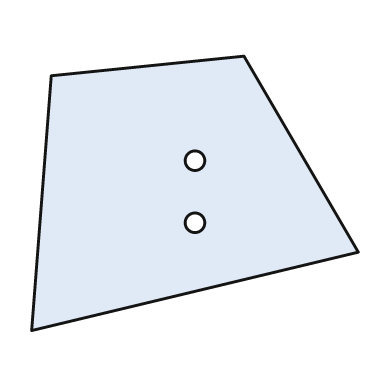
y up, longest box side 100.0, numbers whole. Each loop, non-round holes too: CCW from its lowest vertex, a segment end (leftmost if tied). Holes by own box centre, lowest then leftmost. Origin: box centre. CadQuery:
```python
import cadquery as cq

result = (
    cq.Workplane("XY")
    .moveTo(-50.0, -42.0)
    .lineTo(50.0, -18.0)
    .lineTo(15.0, 42.0)
    .lineTo(-44.0, 36.0)
    .close()
    .moveTo(0.0, -9.0)
    .circle(3.0)
    .moveTo(0.0, 10.0)
    .circle(3.0)
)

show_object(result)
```